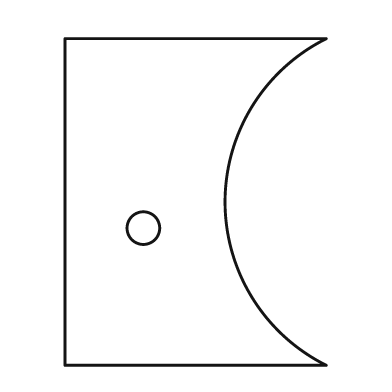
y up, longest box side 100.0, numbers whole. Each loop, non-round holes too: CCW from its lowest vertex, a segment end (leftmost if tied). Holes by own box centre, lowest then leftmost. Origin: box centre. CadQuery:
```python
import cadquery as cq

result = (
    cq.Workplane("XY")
    .moveTo(-40.0, -50.0)
    .lineTo(40.0, -50.0)
    .threePointArc((9.0, 0.0), (40.0, 50.0))
    .lineTo(-40.0, 50.0)
    .close()
    .moveTo(-16.0, -8.0)
    .circle(5.0)
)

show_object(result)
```